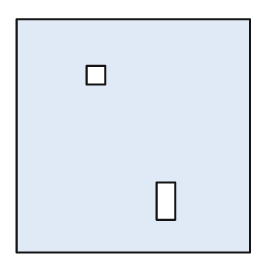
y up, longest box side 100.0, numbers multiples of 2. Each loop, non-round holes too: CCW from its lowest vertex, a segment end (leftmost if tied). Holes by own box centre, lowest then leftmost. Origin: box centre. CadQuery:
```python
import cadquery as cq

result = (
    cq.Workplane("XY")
    .moveTo(-50.0, -50.0)
    .lineTo(50.0, -50.0)
    .lineTo(50.0, 50.0)
    .lineTo(-50.0, 50.0)
    .close()
    .moveTo(10.0, -36.0)
    .lineTo(18.0, -36.0)
    .lineTo(18.0, -20.0)
    .lineTo(10.0, -20.0)
    .close()
    .moveTo(-20.0, 22.0)
    .lineTo(-12.0, 22.0)
    .lineTo(-12.0, 30.0)
    .lineTo(-20.0, 30.0)
    .close()
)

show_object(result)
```